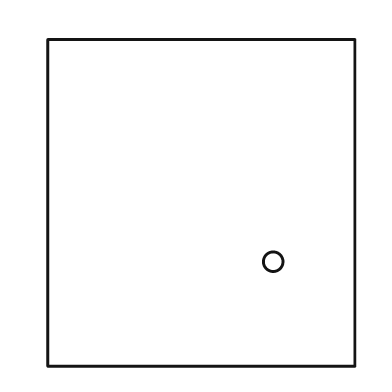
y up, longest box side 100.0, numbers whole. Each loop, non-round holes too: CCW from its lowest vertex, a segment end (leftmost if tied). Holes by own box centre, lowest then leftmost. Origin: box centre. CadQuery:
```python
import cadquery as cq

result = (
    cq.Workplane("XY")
    .moveTo(-47.0, -50.0)
    .lineTo(47.0, -50.0)
    .lineTo(47.0, 50.0)
    .lineTo(-47.0, 50.0)
    .close()
    .moveTo(22.0, -18.0)
    .circle(3.0)
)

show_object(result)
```